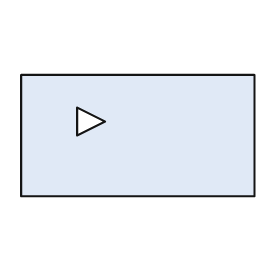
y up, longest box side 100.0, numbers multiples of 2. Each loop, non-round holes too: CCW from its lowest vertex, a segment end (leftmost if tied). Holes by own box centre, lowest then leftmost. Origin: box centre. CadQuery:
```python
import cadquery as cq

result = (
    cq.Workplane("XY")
    .moveTo(-50.0, -26.0)
    .lineTo(50.0, -26.0)
    .lineTo(50.0, 26.0)
    .lineTo(-50.0, 26.0)
    .close()
    .moveTo(-26.0, 0.0)
    .lineTo(-14.0, 6.0)
    .lineTo(-26.0, 12.0)
    .close()
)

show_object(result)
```